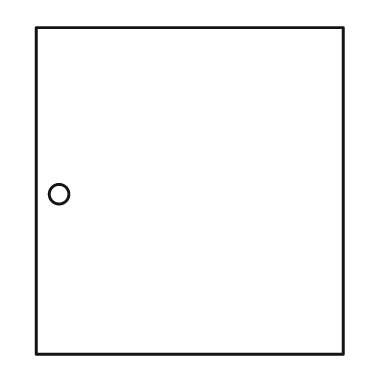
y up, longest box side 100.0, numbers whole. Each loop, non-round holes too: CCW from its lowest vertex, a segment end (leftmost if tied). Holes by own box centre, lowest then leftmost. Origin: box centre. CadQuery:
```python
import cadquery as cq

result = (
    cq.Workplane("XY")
    .moveTo(-47.0, -50.0)
    .lineTo(47.0, -50.0)
    .lineTo(47.0, 50.0)
    .lineTo(-47.0, 50.0)
    .close()
    .moveTo(-40.0, -1.0)
    .circle(3.0)
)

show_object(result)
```